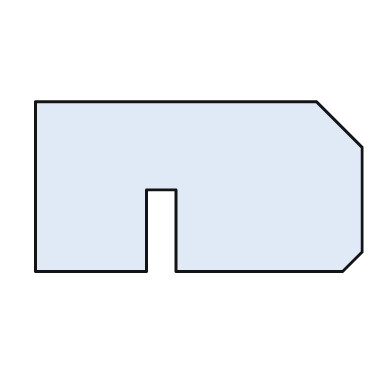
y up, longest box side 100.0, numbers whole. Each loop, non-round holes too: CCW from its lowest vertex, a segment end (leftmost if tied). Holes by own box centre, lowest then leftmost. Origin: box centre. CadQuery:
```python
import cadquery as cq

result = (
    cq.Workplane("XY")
    .moveTo(-50.0, -26.0)
    .lineTo(-16.0, -26.0)
    .lineTo(-16.0, -1.0)
    .lineTo(-7.0, -1.0)
    .lineTo(-7.0, -26.0)
    .lineTo(44.0, -26.0)
    .lineTo(50.0, -20.0)
    .lineTo(50.0, 12.0)
    .lineTo(36.0, 26.0)
    .lineTo(-50.0, 26.0)
    .close()
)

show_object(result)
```